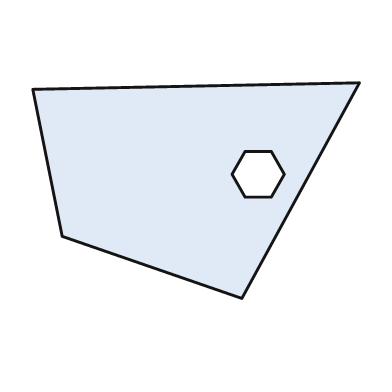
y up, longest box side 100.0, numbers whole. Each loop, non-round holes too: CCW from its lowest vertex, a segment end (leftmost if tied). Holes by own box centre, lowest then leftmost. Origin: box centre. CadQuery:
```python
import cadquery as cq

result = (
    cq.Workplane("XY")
    .moveTo(14.0, -33.0)
    .lineTo(50.0, 33.0)
    .lineTo(-50.0, 31.0)
    .lineTo(-41.0, -14.0)
    .close()
    .moveTo(15.0, -2.0)
    .lineTo(23.0, -2.0)
    .lineTo(27.0, 5.0)
    .lineTo(23.0, 12.0)
    .lineTo(15.0, 12.0)
    .lineTo(11.0, 5.0)
    .close()
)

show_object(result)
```